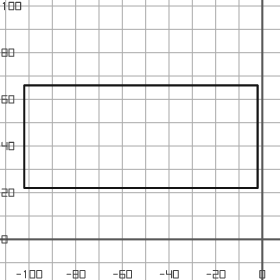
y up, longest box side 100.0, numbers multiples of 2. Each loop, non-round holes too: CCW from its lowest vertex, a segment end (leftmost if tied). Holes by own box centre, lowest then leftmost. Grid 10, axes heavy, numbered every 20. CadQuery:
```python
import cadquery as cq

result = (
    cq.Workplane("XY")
    .moveTo(-102.0, 22.0)
    .lineTo(-2.0, 22.0)
    .lineTo(-2.0, 66.0)
    .lineTo(-102.0, 66.0)
    .close()
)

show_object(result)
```